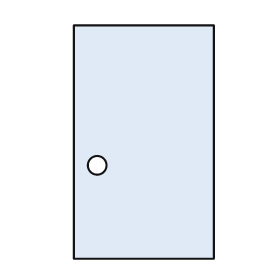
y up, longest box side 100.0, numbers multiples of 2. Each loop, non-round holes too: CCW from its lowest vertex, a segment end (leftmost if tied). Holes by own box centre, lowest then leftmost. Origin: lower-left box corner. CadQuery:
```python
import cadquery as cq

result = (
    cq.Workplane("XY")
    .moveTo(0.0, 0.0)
    .lineTo(60.0, 0.0)
    .lineTo(60.0, 100.0)
    .lineTo(0.0, 100.0)
    .close()
    .moveTo(10.0, 40.0)
    .circle(4.0)
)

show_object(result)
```